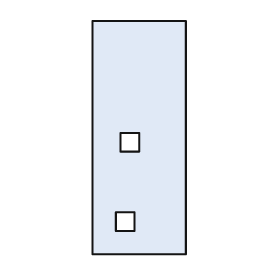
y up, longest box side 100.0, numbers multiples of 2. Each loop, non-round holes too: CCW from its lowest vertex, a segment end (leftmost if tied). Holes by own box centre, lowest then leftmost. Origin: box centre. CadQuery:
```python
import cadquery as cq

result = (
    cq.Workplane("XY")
    .moveTo(-20.0, -50.0)
    .lineTo(20.0, -50.0)
    .lineTo(20.0, 50.0)
    .lineTo(-20.0, 50.0)
    .close()
    .moveTo(-10.0, -40.0)
    .lineTo(-2.0, -40.0)
    .lineTo(-2.0, -32.0)
    .lineTo(-10.0, -32.0)
    .close()
    .moveTo(-8.0, -6.0)
    .lineTo(0.0, -6.0)
    .lineTo(0.0, 2.0)
    .lineTo(-8.0, 2.0)
    .close()
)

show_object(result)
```